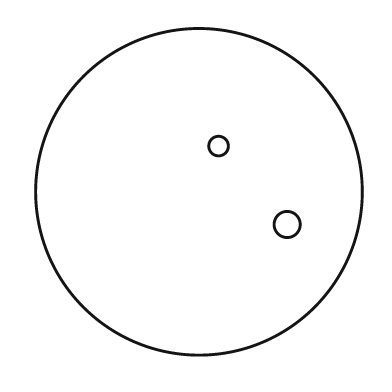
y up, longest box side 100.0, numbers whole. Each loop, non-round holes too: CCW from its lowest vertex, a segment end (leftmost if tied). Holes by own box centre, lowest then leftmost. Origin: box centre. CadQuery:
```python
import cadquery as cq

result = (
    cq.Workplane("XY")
    .moveTo(0.0, 0.0)
    .circle(50.0)
    .moveTo(27.0, -10.0)
    .circle(4.0)
    .moveTo(6.0, 14.0)
    .circle(3.0)
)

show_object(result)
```